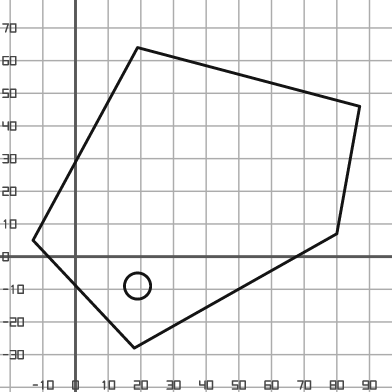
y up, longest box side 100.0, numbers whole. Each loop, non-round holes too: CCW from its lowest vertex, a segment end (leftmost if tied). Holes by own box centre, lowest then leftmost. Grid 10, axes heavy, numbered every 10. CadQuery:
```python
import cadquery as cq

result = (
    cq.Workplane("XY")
    .moveTo(18.0, -28.0)
    .lineTo(80.0, 7.0)
    .lineTo(87.0, 46.0)
    .lineTo(19.0, 64.0)
    .lineTo(-13.0, 5.0)
    .close()
    .moveTo(19.0, -9.0)
    .circle(4.0)
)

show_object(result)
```